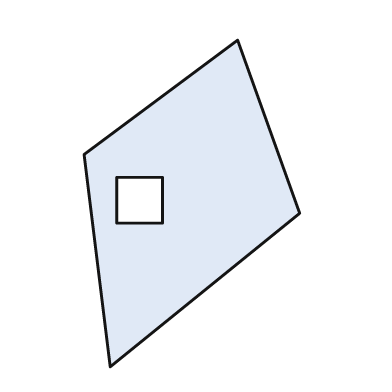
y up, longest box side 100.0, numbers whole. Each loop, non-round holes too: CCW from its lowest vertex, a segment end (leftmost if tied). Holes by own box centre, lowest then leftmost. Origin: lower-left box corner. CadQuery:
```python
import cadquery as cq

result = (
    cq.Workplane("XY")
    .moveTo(8.0, 0.0)
    .lineTo(66.0, 47.0)
    .lineTo(47.0, 100.0)
    .lineTo(0.0, 65.0)
    .close()
    .moveTo(10.0, 44.0)
    .lineTo(24.0, 44.0)
    .lineTo(24.0, 58.0)
    .lineTo(10.0, 58.0)
    .close()
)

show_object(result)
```